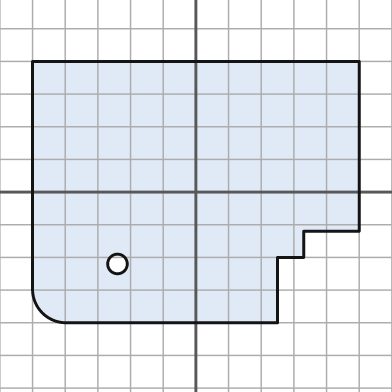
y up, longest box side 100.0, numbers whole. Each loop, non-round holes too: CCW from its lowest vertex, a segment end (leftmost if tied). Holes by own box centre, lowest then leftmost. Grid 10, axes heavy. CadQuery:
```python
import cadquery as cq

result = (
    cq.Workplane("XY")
    .moveTo(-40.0, -40.0)
    .lineTo(25.0, -40.0)
    .lineTo(25.0, -20.0)
    .lineTo(33.0, -20.0)
    .lineTo(33.0, -12.0)
    .lineTo(50.0, -12.0)
    .lineTo(50.0, 40.0)
    .lineTo(-50.0, 40.0)
    .lineTo(-50.0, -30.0)
    .threePointArc((-47.0, -37.0), (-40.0, -40.0))
    .close()
    .moveTo(-24.0, -22.0)
    .circle(3.0)
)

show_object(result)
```